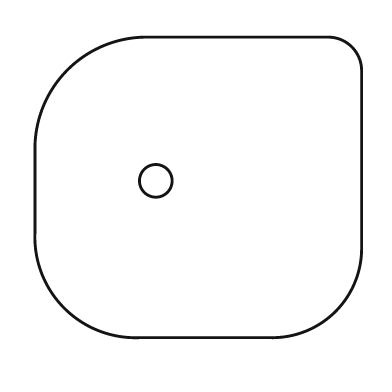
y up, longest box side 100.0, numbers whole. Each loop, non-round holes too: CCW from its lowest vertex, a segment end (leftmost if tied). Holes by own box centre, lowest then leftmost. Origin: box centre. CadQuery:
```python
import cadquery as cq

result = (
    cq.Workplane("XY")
    .moveTo(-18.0, -46.0)
    .lineTo(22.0, -46.0)
    .threePointArc((42.0, -38.0), (50.0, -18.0))
    .lineTo(50.0, 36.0)
    .threePointArc((47.0, 43.0), (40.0, 46.0))
    .lineTo(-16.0, 46.0)
    .threePointArc((-40.0, 36.0), (-50.0, 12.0))
    .lineTo(-50.0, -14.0)
    .threePointArc((-41.0, -37.0), (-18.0, -46.0))
    .close()
    .moveTo(-13.0, 2.0)
    .circle(5.0)
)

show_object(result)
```